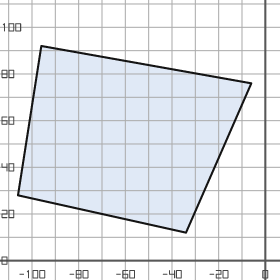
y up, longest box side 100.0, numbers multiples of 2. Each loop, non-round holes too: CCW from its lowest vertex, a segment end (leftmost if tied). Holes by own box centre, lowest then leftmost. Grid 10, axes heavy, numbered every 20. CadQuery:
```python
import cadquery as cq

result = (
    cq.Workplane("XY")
    .moveTo(-34.0, 12.0)
    .lineTo(-6.0, 76.0)
    .lineTo(-96.0, 92.0)
    .lineTo(-106.0, 28.0)
    .close()
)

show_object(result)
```